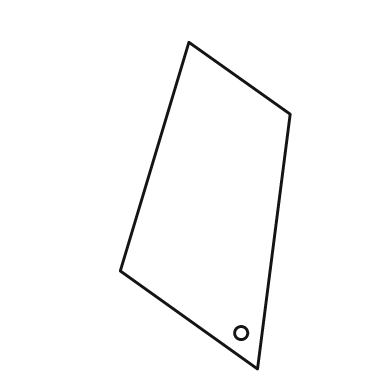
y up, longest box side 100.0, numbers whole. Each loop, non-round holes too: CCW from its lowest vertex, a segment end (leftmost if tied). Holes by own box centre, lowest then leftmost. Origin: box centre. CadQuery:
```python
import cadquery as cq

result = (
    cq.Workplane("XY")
    .moveTo(16.0, -50.0)
    .lineTo(26.0, 28.0)
    .lineTo(-5.0, 50.0)
    .lineTo(-26.0, -20.0)
    .close()
    .moveTo(11.0, -39.0)
    .circle(2.0)
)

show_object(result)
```